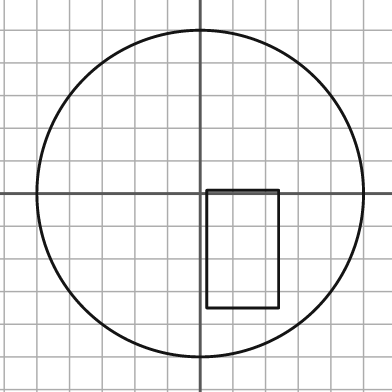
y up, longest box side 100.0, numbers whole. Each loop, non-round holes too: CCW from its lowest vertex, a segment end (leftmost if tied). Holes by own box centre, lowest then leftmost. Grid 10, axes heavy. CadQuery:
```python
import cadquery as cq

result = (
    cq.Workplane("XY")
    .moveTo(0.0, 0.0)
    .circle(50.0)
    .moveTo(2.0, -35.0)
    .lineTo(24.0, -35.0)
    .lineTo(24.0, 1.0)
    .lineTo(2.0, 1.0)
    .close()
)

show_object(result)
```